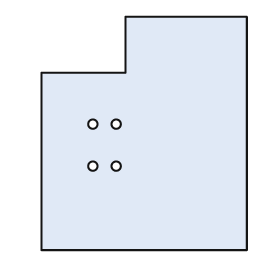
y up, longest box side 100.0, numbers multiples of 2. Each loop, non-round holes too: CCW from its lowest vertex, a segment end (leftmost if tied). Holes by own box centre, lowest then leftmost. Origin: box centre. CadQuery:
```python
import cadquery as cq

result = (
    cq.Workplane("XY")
    .moveTo(-44.0, -50.0)
    .lineTo(44.0, -50.0)
    .lineTo(44.0, 50.0)
    .lineTo(-8.0, 50.0)
    .lineTo(-8.0, 26.0)
    .lineTo(-44.0, 26.0)
    .close()
    .moveTo(-22.0, -14.0)
    .circle(2.0)
    .moveTo(-12.0, -14.0)
    .circle(2.0)
    .moveTo(-22.0, 4.0)
    .circle(2.0)
    .moveTo(-12.0, 4.0)
    .circle(2.0)
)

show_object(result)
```